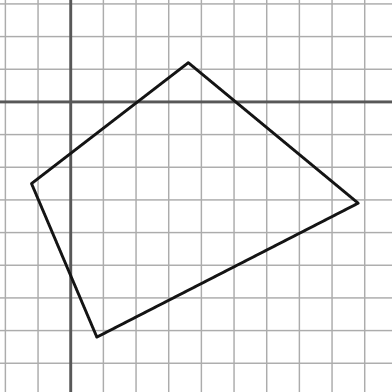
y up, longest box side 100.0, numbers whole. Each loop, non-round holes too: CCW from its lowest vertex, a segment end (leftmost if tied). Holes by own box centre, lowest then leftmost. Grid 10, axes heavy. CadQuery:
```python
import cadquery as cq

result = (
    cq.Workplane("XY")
    .moveTo(8.0, -72.0)
    .lineTo(88.0, -31.0)
    .lineTo(36.0, 12.0)
    .lineTo(-12.0, -25.0)
    .close()
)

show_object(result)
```